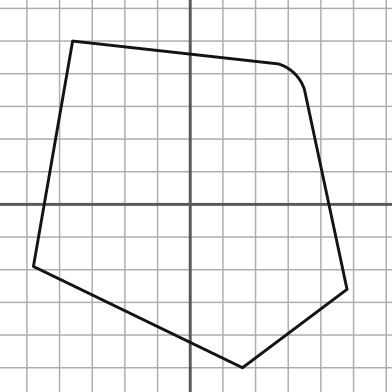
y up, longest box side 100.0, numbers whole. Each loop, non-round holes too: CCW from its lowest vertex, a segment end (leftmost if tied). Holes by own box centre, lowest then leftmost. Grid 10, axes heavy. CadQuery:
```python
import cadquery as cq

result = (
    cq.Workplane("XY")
    .moveTo(16.0, -50.0)
    .lineTo(48.0, -26.0)
    .lineTo(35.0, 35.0)
    .threePointArc((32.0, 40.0), (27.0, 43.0))
    .lineTo(-36.0, 50.0)
    .lineTo(-48.0, -19.0)
    .close()
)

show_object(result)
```